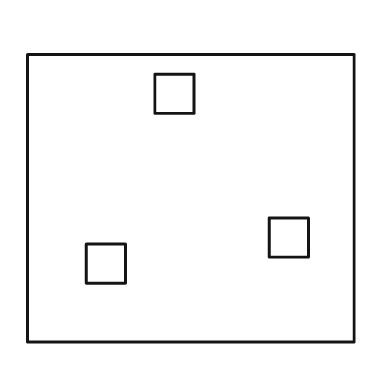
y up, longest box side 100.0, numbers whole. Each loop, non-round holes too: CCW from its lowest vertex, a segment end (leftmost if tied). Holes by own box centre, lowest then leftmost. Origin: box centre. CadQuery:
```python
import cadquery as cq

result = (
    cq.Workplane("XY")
    .moveTo(-50.0, -44.0)
    .lineTo(50.0, -44.0)
    .lineTo(50.0, 44.0)
    .lineTo(-50.0, 44.0)
    .close()
    .moveTo(-32.0, -26.0)
    .lineTo(-20.0, -26.0)
    .lineTo(-20.0, -14.0)
    .lineTo(-32.0, -14.0)
    .close()
    .moveTo(24.0, -18.0)
    .lineTo(36.0, -18.0)
    .lineTo(36.0, -6.0)
    .lineTo(24.0, -6.0)
    .close()
    .moveTo(-11.0, 26.0)
    .lineTo(1.0, 26.0)
    .lineTo(1.0, 38.0)
    .lineTo(-11.0, 38.0)
    .close()
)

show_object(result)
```